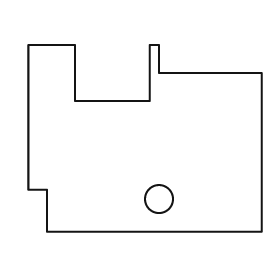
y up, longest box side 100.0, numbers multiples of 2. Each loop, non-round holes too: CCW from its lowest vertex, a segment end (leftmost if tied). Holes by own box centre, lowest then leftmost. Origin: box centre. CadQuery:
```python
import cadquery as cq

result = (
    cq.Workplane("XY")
    .moveTo(-42.0, -40.0)
    .lineTo(50.0, -40.0)
    .lineTo(50.0, 28.0)
    .lineTo(6.0, 28.0)
    .lineTo(6.0, 40.0)
    .lineTo(2.0, 40.0)
    .lineTo(2.0, 16.0)
    .lineTo(-30.0, 16.0)
    .lineTo(-30.0, 40.0)
    .lineTo(-50.0, 40.0)
    .lineTo(-50.0, -22.0)
    .lineTo(-42.0, -22.0)
    .close()
    .moveTo(6.0, -26.0)
    .circle(6.0)
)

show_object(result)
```